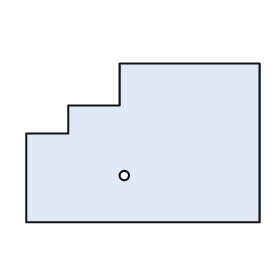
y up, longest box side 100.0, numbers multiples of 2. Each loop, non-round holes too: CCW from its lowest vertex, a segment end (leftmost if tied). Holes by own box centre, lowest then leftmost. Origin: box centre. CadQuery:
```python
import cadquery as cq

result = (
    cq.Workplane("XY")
    .moveTo(-50.0, -34.0)
    .lineTo(50.0, -34.0)
    .lineTo(50.0, 34.0)
    .lineTo(-10.0, 34.0)
    .lineTo(-10.0, 16.0)
    .lineTo(-32.0, 16.0)
    .lineTo(-32.0, 4.0)
    .lineTo(-50.0, 4.0)
    .close()
    .moveTo(-8.0, -14.0)
    .circle(2.0)
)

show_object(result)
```